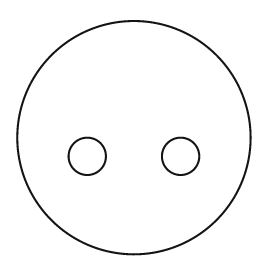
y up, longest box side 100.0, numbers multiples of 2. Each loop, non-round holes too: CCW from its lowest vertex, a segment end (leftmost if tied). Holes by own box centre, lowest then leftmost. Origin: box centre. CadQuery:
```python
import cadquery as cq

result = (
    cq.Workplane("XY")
    .moveTo(0.0, 0.0)
    .circle(50.0)
    .moveTo(-20.0, -8.0)
    .circle(8.0)
    .moveTo(20.0, -8.0)
    .circle(8.0)
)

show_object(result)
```